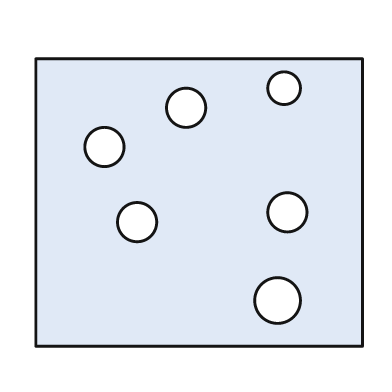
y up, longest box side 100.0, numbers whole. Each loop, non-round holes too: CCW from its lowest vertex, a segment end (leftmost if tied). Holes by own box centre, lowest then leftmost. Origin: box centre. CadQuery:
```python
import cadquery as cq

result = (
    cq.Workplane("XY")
    .moveTo(-50.0, -44.0)
    .lineTo(50.0, -44.0)
    .lineTo(50.0, 44.0)
    .lineTo(-50.0, 44.0)
    .close()
    .moveTo(24.0, -30.0)
    .circle(7.0)
    .moveTo(-19.0, -6.0)
    .circle(6.0)
    .moveTo(27.0, -3.0)
    .circle(6.0)
    .moveTo(-29.0, 17.0)
    .circle(6.0)
    .moveTo(-4.0, 29.0)
    .circle(6.0)
    .moveTo(26.0, 35.0)
    .circle(5.0)
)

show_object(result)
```